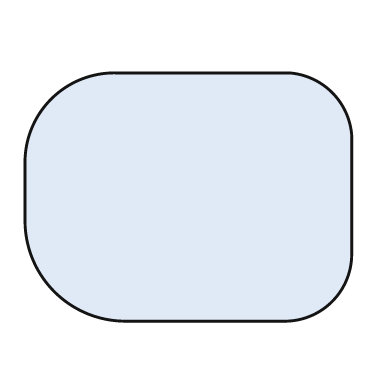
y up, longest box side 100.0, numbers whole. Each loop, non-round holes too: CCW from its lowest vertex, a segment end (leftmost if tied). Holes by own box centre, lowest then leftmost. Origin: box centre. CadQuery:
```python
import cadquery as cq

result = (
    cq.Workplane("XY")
    .moveTo(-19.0, -38.0)
    .lineTo(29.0, -38.0)
    .threePointArc((44.0, -32.0), (50.0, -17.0))
    .lineTo(50.0, 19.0)
    .threePointArc((44.0, 32.0), (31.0, 38.0))
    .lineTo(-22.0, 38.0)
    .threePointArc((-42.0, 30.0), (-50.0, 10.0))
    .lineTo(-50.0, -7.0)
    .threePointArc((-41.0, -29.0), (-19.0, -38.0))
    .close()
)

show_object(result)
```